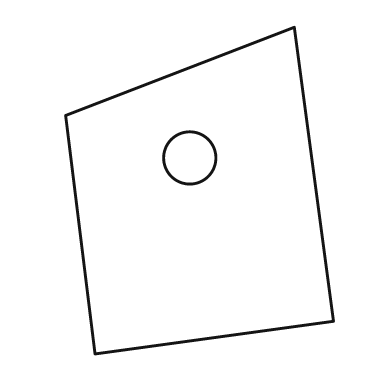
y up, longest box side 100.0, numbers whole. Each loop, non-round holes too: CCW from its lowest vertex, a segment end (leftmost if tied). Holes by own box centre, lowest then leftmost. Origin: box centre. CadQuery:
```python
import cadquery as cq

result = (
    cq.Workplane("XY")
    .moveTo(-32.0, -50.0)
    .lineTo(41.0, -40.0)
    .lineTo(29.0, 50.0)
    .lineTo(-41.0, 23.0)
    .close()
    .moveTo(-3.0, 10.0)
    .circle(8.0)
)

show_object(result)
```